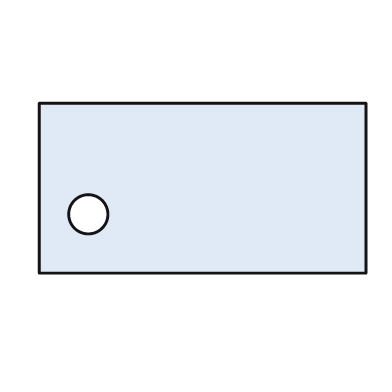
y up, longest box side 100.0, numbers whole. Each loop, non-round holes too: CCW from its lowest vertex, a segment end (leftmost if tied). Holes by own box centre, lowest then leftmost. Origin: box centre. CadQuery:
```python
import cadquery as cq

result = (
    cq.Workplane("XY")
    .moveTo(-50.0, -26.0)
    .lineTo(50.0, -26.0)
    .lineTo(50.0, 26.0)
    .lineTo(-50.0, 26.0)
    .close()
    .moveTo(-35.0, -8.0)
    .circle(6.0)
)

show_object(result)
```